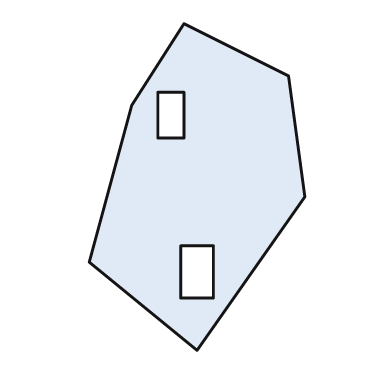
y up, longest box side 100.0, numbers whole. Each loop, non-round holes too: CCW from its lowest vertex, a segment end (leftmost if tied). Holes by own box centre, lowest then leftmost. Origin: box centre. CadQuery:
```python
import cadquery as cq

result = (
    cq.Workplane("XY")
    .moveTo(0.0, -50.0)
    .lineTo(33.0, -3.0)
    .lineTo(28.0, 34.0)
    .lineTo(-4.0, 50.0)
    .lineTo(-20.0, 25.0)
    .lineTo(-33.0, -23.0)
    .close()
    .moveTo(-5.0, -34.0)
    .lineTo(5.0, -34.0)
    .lineTo(5.0, -18.0)
    .lineTo(-5.0, -18.0)
    .close()
    .moveTo(-12.0, 15.0)
    .lineTo(-4.0, 15.0)
    .lineTo(-4.0, 29.0)
    .lineTo(-12.0, 29.0)
    .close()
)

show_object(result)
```